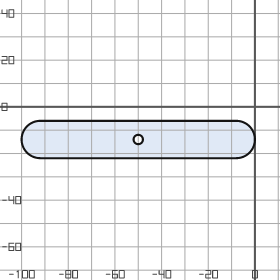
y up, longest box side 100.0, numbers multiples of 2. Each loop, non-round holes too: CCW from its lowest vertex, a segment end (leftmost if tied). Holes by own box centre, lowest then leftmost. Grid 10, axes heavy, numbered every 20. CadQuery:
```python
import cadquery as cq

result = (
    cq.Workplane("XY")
    .moveTo(-92.0, -22.0)
    .lineTo(-8.0, -22.0)
    .threePointArc((0.0, -14.0), (-8.0, -6.0))
    .lineTo(-92.0, -6.0)
    .threePointArc((-100.0, -14.0), (-92.0, -22.0))
    .close()
    .moveTo(-50.0, -14.0)
    .circle(2.0)
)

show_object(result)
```